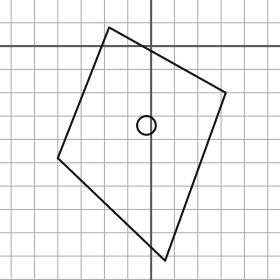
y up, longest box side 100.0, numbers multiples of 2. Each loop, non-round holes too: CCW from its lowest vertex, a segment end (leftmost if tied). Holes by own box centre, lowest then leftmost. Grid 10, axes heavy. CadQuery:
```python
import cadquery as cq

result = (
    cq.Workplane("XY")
    .moveTo(6.0, -92.0)
    .lineTo(32.0, -20.0)
    .lineTo(-18.0, 8.0)
    .lineTo(-40.0, -48.0)
    .close()
    .moveTo(-2.0, -34.0)
    .circle(4.0)
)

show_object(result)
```